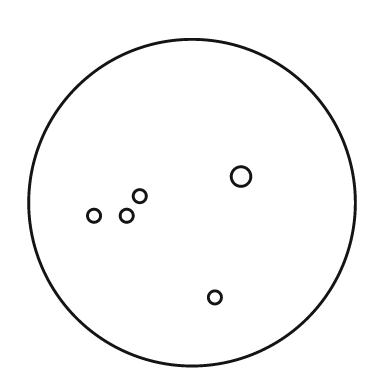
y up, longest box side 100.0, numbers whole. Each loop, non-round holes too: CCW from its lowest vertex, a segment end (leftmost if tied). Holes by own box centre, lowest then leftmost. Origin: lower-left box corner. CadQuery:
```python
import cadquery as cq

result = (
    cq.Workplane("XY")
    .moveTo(50.0, 50.0)
    .circle(50.0)
    .moveTo(57.0, 21.0)
    .circle(2.0)
    .moveTo(20.0, 46.0)
    .circle(2.0)
    .moveTo(30.0, 46.0)
    .circle(2.0)
    .moveTo(34.0, 52.0)
    .circle(2.0)
    .moveTo(65.0, 58.0)
    .circle(3.0)
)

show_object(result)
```